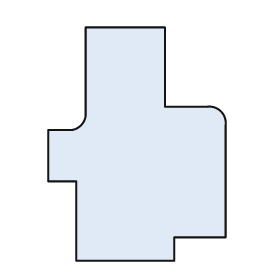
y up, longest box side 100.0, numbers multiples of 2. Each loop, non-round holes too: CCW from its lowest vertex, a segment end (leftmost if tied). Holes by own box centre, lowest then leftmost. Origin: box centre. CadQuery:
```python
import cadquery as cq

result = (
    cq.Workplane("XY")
    .moveTo(-26.0, -50.0)
    .lineTo(16.0, -50.0)
    .lineTo(16.0, -40.0)
    .lineTo(38.0, -40.0)
    .lineTo(38.0, 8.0)
    .threePointArc((36.0, 14.0), (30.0, 16.0))
    .lineTo(12.0, 16.0)
    .lineTo(12.0, 50.0)
    .lineTo(-22.0, 50.0)
    .lineTo(-22.0, 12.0)
    .threePointArc((-24.0, 8.0), (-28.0, 6.0))
    .lineTo(-38.0, 6.0)
    .lineTo(-38.0, -16.0)
    .lineTo(-26.0, -16.0)
    .close()
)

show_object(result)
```